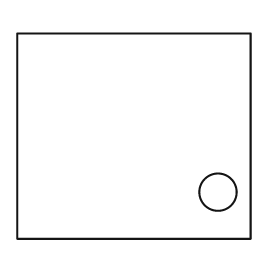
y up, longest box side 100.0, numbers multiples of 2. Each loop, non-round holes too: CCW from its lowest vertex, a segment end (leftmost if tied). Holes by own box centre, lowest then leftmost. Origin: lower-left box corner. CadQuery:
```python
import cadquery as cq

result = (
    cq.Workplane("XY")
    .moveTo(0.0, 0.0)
    .lineTo(100.0, 0.0)
    .lineTo(100.0, 88.0)
    .lineTo(0.0, 88.0)
    .close()
    .moveTo(86.0, 20.0)
    .circle(8.0)
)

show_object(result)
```